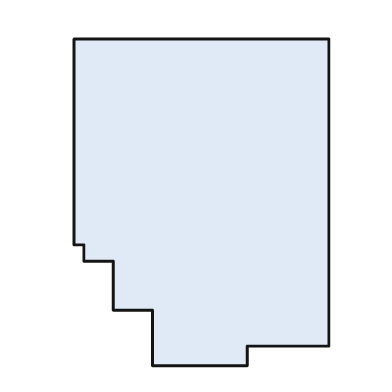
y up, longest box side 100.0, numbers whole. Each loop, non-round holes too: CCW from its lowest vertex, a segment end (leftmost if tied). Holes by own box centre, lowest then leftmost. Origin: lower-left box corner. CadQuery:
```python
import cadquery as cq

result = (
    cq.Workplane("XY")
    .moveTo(24.0, 0.0)
    .lineTo(53.0, 0.0)
    .lineTo(53.0, 6.0)
    .lineTo(78.0, 6.0)
    .lineTo(78.0, 100.0)
    .lineTo(0.0, 100.0)
    .lineTo(0.0, 37.0)
    .lineTo(3.0, 37.0)
    .lineTo(3.0, 32.0)
    .lineTo(12.0, 32.0)
    .lineTo(12.0, 17.0)
    .lineTo(24.0, 17.0)
    .close()
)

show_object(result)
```